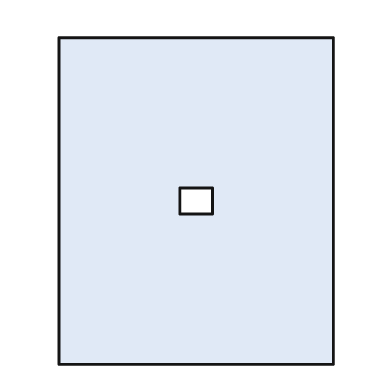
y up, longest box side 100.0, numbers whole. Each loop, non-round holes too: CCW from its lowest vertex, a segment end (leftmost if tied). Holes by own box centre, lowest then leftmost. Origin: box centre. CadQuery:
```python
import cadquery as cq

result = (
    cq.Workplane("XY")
    .moveTo(-42.0, -50.0)
    .lineTo(42.0, -50.0)
    .lineTo(42.0, 50.0)
    .lineTo(-42.0, 50.0)
    .close()
    .moveTo(-5.0, -4.0)
    .lineTo(5.0, -4.0)
    .lineTo(5.0, 4.0)
    .lineTo(-5.0, 4.0)
    .close()
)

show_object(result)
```